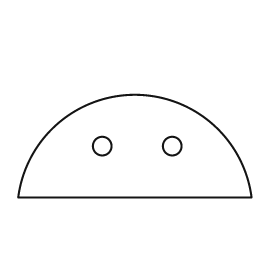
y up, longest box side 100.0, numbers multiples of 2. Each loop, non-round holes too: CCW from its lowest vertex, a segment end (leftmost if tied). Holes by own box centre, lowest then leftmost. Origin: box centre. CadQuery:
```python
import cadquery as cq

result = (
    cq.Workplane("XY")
    .moveTo(-50.0, -22.0)
    .lineTo(50.0, -22.0)
    .threePointArc((0.0, 22.0), (-50.0, -22.0))
    .close()
    .moveTo(-14.0, 0.0)
    .circle(4.0)
    .moveTo(16.0, 0.0)
    .circle(4.0)
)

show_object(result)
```